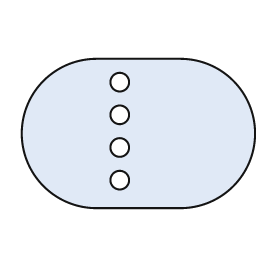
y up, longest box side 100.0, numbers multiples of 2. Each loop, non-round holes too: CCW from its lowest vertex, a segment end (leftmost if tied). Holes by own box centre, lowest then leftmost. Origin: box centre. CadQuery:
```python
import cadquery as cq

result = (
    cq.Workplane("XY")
    .moveTo(-18.0, -32.0)
    .lineTo(18.0, -32.0)
    .threePointArc((50.0, 0.0), (18.0, 32.0))
    .lineTo(-18.0, 32.0)
    .threePointArc((-50.0, 0.0), (-18.0, -32.0))
    .close()
    .moveTo(-8.0, -20.0)
    .circle(4.0)
    .moveTo(-8.0, -6.0)
    .circle(4.0)
    .moveTo(-8.0, 8.0)
    .circle(4.0)
    .moveTo(-8.0, 22.0)
    .circle(4.0)
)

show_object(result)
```